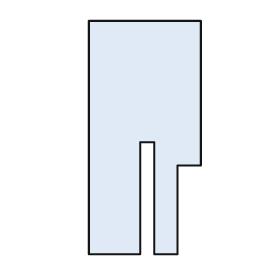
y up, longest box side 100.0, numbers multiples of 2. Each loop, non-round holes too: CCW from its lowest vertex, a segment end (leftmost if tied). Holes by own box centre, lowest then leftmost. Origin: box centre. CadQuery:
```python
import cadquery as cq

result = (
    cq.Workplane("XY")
    .moveTo(-24.0, -50.0)
    .lineTo(-2.0, -50.0)
    .lineTo(-2.0, -2.0)
    .lineTo(4.0, -2.0)
    .lineTo(4.0, -50.0)
    .lineTo(14.0, -50.0)
    .lineTo(14.0, -12.0)
    .lineTo(24.0, -12.0)
    .lineTo(24.0, 50.0)
    .lineTo(-24.0, 50.0)
    .close()
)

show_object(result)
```